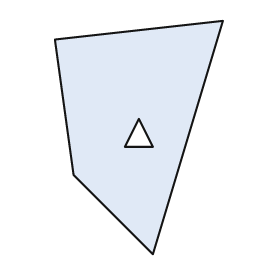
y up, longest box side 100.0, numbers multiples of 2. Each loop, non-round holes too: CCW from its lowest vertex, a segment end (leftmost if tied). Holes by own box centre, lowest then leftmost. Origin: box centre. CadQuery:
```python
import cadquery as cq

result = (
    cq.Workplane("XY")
    .moveTo(6.0, -50.0)
    .lineTo(36.0, 50.0)
    .lineTo(-36.0, 42.0)
    .lineTo(-28.0, -16.0)
    .close()
    .moveTo(-6.0, -4.0)
    .lineTo(6.0, -4.0)
    .lineTo(0.0, 8.0)
    .close()
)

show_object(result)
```